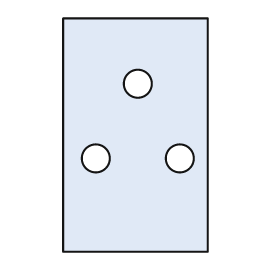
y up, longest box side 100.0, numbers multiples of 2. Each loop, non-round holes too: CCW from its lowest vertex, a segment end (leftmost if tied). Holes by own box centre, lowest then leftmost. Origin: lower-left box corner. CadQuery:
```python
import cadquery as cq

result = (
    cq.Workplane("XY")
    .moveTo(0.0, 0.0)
    .lineTo(62.0, 0.0)
    .lineTo(62.0, 100.0)
    .lineTo(0.0, 100.0)
    .close()
    .moveTo(14.0, 40.0)
    .circle(6.0)
    .moveTo(50.0, 40.0)
    .circle(6.0)
    .moveTo(32.0, 72.0)
    .circle(6.0)
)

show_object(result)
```